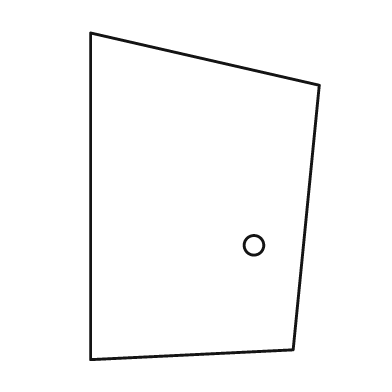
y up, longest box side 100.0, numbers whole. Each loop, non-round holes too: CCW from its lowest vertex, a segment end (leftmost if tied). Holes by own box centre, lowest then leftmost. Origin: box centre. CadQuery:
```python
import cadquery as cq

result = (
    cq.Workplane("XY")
    .moveTo(-35.0, -50.0)
    .lineTo(27.0, -47.0)
    .lineTo(35.0, 34.0)
    .lineTo(-35.0, 50.0)
    .close()
    .moveTo(15.0, -15.0)
    .circle(3.0)
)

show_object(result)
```